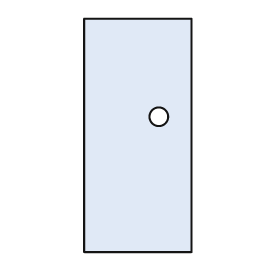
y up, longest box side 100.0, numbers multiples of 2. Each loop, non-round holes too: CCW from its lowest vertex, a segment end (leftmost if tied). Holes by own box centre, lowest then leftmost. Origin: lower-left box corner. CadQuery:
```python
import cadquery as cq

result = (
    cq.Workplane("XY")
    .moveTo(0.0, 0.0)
    .lineTo(46.0, 0.0)
    .lineTo(46.0, 100.0)
    .lineTo(0.0, 100.0)
    .close()
    .moveTo(32.0, 58.0)
    .circle(4.0)
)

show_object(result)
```